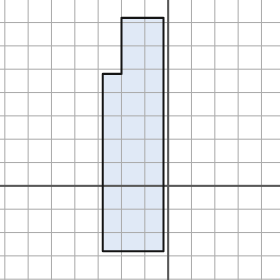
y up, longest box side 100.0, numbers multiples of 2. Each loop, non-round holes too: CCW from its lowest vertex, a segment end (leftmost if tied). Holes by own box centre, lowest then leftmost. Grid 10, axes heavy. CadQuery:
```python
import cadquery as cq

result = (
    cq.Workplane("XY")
    .moveTo(-28.0, -28.0)
    .lineTo(-2.0, -28.0)
    .lineTo(-2.0, 72.0)
    .lineTo(-20.0, 72.0)
    .lineTo(-20.0, 48.0)
    .lineTo(-28.0, 48.0)
    .close()
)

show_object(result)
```